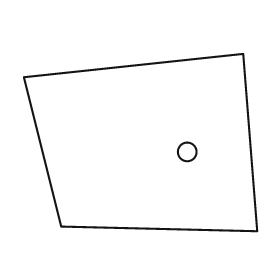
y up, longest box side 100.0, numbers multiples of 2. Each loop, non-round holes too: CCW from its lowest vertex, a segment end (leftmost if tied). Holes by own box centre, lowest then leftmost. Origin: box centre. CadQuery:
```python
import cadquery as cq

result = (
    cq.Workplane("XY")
    .moveTo(50.0, -38.0)
    .lineTo(44.0, 38.0)
    .lineTo(-50.0, 28.0)
    .lineTo(-34.0, -36.0)
    .close()
    .moveTo(20.0, -4.0)
    .circle(4.0)
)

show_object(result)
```